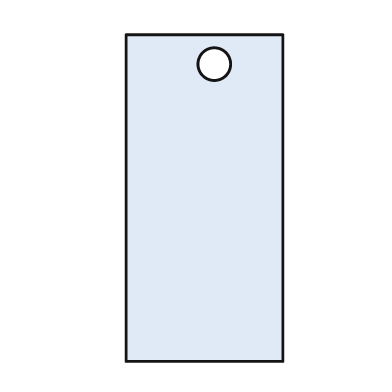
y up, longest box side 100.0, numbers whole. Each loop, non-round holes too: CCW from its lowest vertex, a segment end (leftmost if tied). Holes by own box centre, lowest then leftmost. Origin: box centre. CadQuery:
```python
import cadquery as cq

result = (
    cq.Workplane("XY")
    .moveTo(-24.0, -50.0)
    .lineTo(24.0, -50.0)
    .lineTo(24.0, 50.0)
    .lineTo(-24.0, 50.0)
    .close()
    .moveTo(3.0, 41.0)
    .circle(5.0)
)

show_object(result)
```